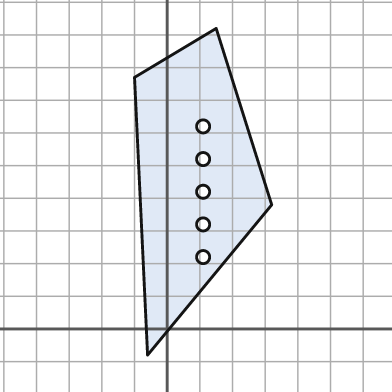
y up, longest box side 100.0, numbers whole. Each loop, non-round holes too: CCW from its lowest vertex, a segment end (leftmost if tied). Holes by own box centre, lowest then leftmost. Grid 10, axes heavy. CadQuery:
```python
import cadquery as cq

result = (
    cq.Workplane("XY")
    .moveTo(-6.0, -8.0)
    .lineTo(32.0, 38.0)
    .lineTo(15.0, 92.0)
    .lineTo(-10.0, 77.0)
    .close()
    .moveTo(11.0, 22.0)
    .circle(2.0)
    .moveTo(11.0, 32.0)
    .circle(2.0)
    .moveTo(11.0, 42.0)
    .circle(2.0)
    .moveTo(11.0, 52.0)
    .circle(2.0)
    .moveTo(11.0, 62.0)
    .circle(2.0)
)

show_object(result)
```